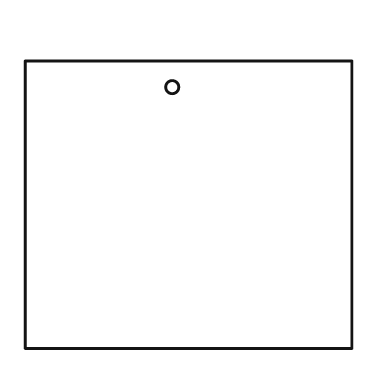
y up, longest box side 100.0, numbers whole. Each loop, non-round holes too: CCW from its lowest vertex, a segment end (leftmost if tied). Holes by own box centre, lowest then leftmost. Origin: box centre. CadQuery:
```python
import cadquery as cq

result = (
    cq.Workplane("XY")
    .moveTo(-50.0, -44.0)
    .lineTo(50.0, -44.0)
    .lineTo(50.0, 44.0)
    .lineTo(-50.0, 44.0)
    .close()
    .moveTo(-5.0, 36.0)
    .circle(2.0)
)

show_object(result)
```